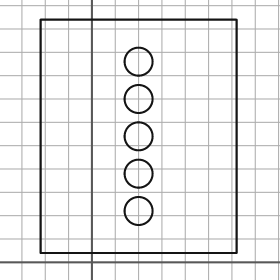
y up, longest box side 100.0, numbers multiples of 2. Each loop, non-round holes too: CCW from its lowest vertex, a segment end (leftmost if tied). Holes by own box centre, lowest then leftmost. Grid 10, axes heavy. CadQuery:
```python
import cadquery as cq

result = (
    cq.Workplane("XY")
    .moveTo(-22.0, 4.0)
    .lineTo(62.0, 4.0)
    .lineTo(62.0, 104.0)
    .lineTo(-22.0, 104.0)
    .close()
    .moveTo(20.0, 22.0)
    .circle(6.0)
    .moveTo(20.0, 38.0)
    .circle(6.0)
    .moveTo(20.0, 54.0)
    .circle(6.0)
    .moveTo(20.0, 70.0)
    .circle(6.0)
    .moveTo(20.0, 86.0)
    .circle(6.0)
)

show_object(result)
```